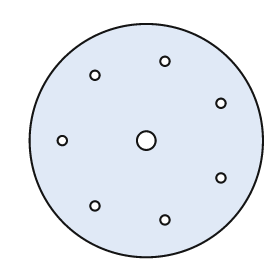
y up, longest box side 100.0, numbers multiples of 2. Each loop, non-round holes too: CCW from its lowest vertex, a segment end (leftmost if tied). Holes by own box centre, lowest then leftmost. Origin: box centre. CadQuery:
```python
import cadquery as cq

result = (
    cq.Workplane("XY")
    .moveTo(0.0, 0.0)
    .circle(50.0)
    .moveTo(8.0, -34.0)
    .circle(2.0)
    .moveTo(-22.0, -28.0)
    .circle(2.0)
    .moveTo(32.0, -16.0)
    .circle(2.0)
    .moveTo(-36.0, 0.0)
    .circle(2.0)
    .moveTo(0.0, 0.0)
    .circle(4.0)
    .moveTo(32.0, 16.0)
    .circle(2.0)
    .moveTo(-22.0, 28.0)
    .circle(2.0)
    .moveTo(8.0, 34.0)
    .circle(2.0)
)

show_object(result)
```